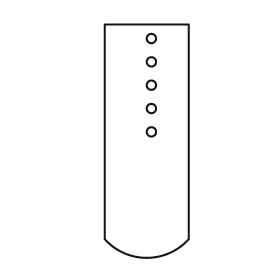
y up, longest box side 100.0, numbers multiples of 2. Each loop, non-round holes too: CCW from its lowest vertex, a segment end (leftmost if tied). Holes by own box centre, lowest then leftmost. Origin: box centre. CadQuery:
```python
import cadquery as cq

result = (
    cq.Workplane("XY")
    .moveTo(-18.0, -42.0)
    .threePointArc((0.0, -50.0), (18.0, -42.0))
    .lineTo(18.0, 50.0)
    .lineTo(-18.0, 50.0)
    .close()
    .moveTo(2.0, 4.0)
    .circle(2.0)
    .moveTo(2.0, 14.0)
    .circle(2.0)
    .moveTo(2.0, 24.0)
    .circle(2.0)
    .moveTo(2.0, 34.0)
    .circle(2.0)
    .moveTo(2.0, 44.0)
    .circle(2.0)
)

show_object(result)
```